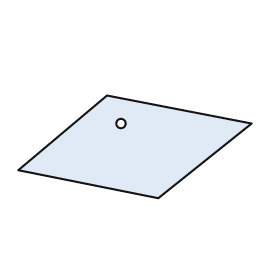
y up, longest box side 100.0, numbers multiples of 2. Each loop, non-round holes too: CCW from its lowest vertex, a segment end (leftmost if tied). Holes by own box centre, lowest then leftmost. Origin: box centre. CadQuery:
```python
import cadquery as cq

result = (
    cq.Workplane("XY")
    .moveTo(10.0, -22.0)
    .lineTo(50.0, 10.0)
    .lineTo(-12.0, 22.0)
    .lineTo(-50.0, -10.0)
    .close()
    .moveTo(-6.0, 10.0)
    .circle(2.0)
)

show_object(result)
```